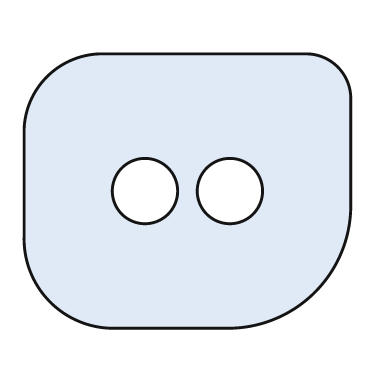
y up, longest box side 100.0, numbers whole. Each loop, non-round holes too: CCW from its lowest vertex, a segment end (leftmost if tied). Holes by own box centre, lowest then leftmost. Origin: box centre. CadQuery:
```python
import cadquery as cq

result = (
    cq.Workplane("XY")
    .moveTo(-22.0, -42.0)
    .lineTo(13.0, -42.0)
    .threePointArc((39.0, -31.0), (50.0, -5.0))
    .lineTo(50.0, 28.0)
    .threePointArc((46.0, 38.0), (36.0, 42.0))
    .lineTo(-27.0, 42.0)
    .threePointArc((-43.0, 35.0), (-50.0, 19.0))
    .lineTo(-50.0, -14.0)
    .threePointArc((-42.0, -34.0), (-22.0, -42.0))
    .close()
    .moveTo(-13.0, 0.0)
    .circle(10.0)
    .moveTo(13.0, 0.0)
    .circle(10.0)
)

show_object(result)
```